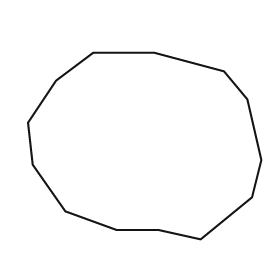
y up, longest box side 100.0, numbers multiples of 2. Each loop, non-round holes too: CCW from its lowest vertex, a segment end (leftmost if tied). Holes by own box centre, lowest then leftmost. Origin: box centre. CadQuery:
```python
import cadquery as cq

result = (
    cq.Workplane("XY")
    .moveTo(24.0, -40.0)
    .lineTo(46.0, -22.0)
    .lineTo(50.0, -6.0)
    .lineTo(44.0, 20.0)
    .lineTo(34.0, 32.0)
    .lineTo(4.0, 40.0)
    .lineTo(-22.0, 40.0)
    .lineTo(-38.0, 28.0)
    .lineTo(-50.0, 10.0)
    .lineTo(-48.0, -8.0)
    .lineTo(-34.0, -28.0)
    .lineTo(-12.0, -36.0)
    .lineTo(6.0, -36.0)
    .close()
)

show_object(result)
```